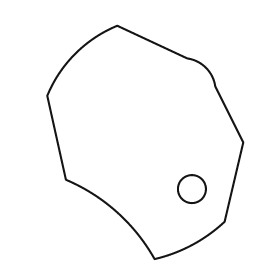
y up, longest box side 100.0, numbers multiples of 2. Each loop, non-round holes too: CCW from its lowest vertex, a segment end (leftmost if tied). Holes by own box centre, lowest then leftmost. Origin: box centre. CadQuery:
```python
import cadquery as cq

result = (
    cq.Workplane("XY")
    .moveTo(4.0, -50.0)
    .threePointArc((20.0, -44.0), (34.0, -34.0))
    .lineTo(42.0, 0.0)
    .lineTo(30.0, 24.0)
    .threePointArc((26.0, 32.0), (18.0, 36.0))
    .lineTo(-12.0, 50.0)
    .threePointArc((-30.0, 38.0), (-42.0, 20.0))
    .lineTo(-34.0, -16.0)
    .threePointArc((-12.0, -30.0), (4.0, -50.0))
    .close()
    .moveTo(20.0, -20.0)
    .circle(6.0)
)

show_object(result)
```